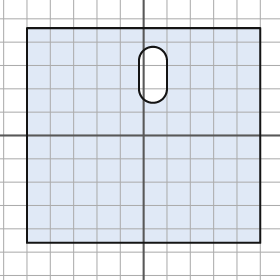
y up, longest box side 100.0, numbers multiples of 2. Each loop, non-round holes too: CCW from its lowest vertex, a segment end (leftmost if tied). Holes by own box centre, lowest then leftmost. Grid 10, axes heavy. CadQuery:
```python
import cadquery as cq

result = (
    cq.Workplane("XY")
    .moveTo(-50.0, -46.0)
    .lineTo(50.0, -46.0)
    .lineTo(50.0, 46.0)
    .lineTo(-50.0, 46.0)
    .close()
    .moveTo(-2.0, 20.0)
    .threePointArc((4.0, 14.0), (10.0, 20.0))
    .lineTo(10.0, 32.0)
    .threePointArc((4.0, 38.0), (-2.0, 32.0))
    .close()
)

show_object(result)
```